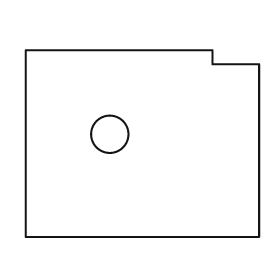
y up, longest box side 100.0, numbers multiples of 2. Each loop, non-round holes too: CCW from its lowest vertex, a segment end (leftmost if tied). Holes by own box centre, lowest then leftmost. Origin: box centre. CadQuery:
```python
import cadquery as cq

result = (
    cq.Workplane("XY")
    .moveTo(-50.0, -40.0)
    .lineTo(50.0, -40.0)
    .lineTo(50.0, 34.0)
    .lineTo(30.0, 34.0)
    .lineTo(30.0, 40.0)
    .lineTo(-50.0, 40.0)
    .close()
    .moveTo(-14.0, 4.0)
    .circle(8.0)
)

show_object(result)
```